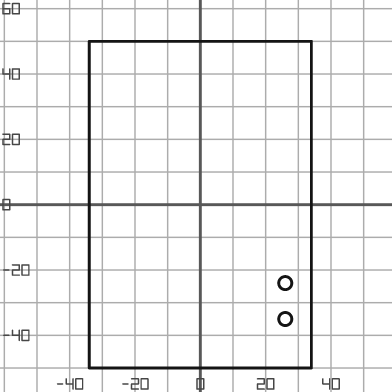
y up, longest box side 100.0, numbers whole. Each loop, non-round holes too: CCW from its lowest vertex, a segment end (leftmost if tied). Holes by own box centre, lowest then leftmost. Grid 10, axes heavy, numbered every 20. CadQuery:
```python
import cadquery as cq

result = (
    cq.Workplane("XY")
    .moveTo(-34.0, -50.0)
    .lineTo(34.0, -50.0)
    .lineTo(34.0, 50.0)
    .lineTo(-34.0, 50.0)
    .close()
    .moveTo(26.0, -35.0)
    .circle(2.0)
    .moveTo(26.0, -24.0)
    .circle(2.0)
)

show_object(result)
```